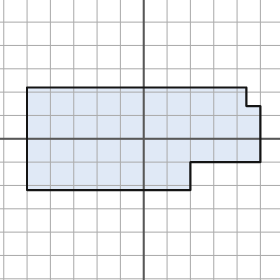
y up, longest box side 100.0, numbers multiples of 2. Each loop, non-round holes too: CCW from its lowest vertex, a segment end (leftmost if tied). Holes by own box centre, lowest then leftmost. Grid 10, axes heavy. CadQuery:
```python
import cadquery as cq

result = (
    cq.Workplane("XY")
    .moveTo(-50.0, -22.0)
    .lineTo(20.0, -22.0)
    .lineTo(20.0, -10.0)
    .lineTo(50.0, -10.0)
    .lineTo(50.0, 14.0)
    .lineTo(44.0, 14.0)
    .lineTo(44.0, 22.0)
    .lineTo(-50.0, 22.0)
    .close()
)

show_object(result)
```